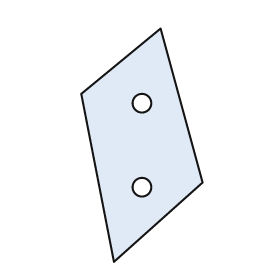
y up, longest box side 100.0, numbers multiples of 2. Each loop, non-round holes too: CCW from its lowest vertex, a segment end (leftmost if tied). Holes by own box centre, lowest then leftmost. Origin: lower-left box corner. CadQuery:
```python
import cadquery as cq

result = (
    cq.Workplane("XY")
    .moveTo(14.0, 0.0)
    .lineTo(52.0, 34.0)
    .lineTo(34.0, 100.0)
    .lineTo(0.0, 72.0)
    .close()
    .moveTo(26.0, 32.0)
    .circle(4.0)
    .moveTo(26.0, 68.0)
    .circle(4.0)
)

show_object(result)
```